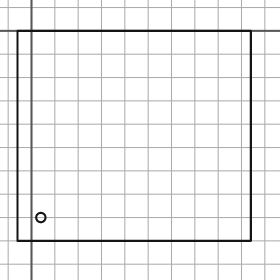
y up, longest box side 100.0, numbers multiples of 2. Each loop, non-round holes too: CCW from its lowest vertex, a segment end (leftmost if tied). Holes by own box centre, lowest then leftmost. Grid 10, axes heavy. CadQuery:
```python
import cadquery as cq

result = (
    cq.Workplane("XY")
    .moveTo(-6.0, -90.0)
    .lineTo(94.0, -90.0)
    .lineTo(94.0, 0.0)
    .lineTo(-6.0, 0.0)
    .close()
    .moveTo(4.0, -80.0)
    .circle(2.0)
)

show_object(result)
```